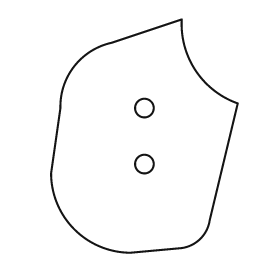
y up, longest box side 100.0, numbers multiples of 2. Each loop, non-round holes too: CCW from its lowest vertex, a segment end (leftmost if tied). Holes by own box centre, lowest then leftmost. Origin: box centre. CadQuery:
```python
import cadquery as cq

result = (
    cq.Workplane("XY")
    .moveTo(-6.0, -50.0)
    .lineTo(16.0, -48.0)
    .threePointArc((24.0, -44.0), (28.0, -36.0))
    .lineTo(40.0, 14.0)
    .threePointArc((22.0, 28.0), (16.0, 50.0))
    .lineTo(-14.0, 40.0)
    .threePointArc((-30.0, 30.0), (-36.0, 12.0))
    .lineTo(-40.0, -16.0)
    .threePointArc((-30.0, -40.0), (-6.0, -50.0))
    .close()
    .moveTo(0.0, -12.0)
    .circle(4.0)
    .moveTo(0.0, 12.0)
    .circle(4.0)
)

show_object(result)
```